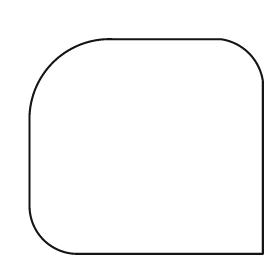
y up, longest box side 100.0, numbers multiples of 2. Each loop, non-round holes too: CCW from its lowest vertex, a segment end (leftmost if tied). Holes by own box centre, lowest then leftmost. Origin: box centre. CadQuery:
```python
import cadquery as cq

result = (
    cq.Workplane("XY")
    .moveTo(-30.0, -46.0)
    .lineTo(50.0, -46.0)
    .lineTo(50.0, 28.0)
    .threePointArc((44.0, 40.0), (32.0, 46.0))
    .lineTo(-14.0, 46.0)
    .threePointArc((-40.0, 36.0), (-50.0, 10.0))
    .lineTo(-50.0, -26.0)
    .threePointArc((-44.0, -40.0), (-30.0, -46.0))
    .close()
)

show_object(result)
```